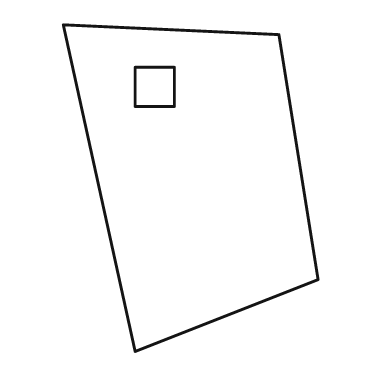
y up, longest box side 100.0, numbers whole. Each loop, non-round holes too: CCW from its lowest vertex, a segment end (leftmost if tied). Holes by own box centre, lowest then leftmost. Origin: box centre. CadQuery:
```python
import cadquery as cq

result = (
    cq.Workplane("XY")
    .moveTo(-17.0, -50.0)
    .lineTo(39.0, -28.0)
    .lineTo(27.0, 47.0)
    .lineTo(-39.0, 50.0)
    .close()
    .moveTo(-17.0, 25.0)
    .lineTo(-5.0, 25.0)
    .lineTo(-5.0, 37.0)
    .lineTo(-17.0, 37.0)
    .close()
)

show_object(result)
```